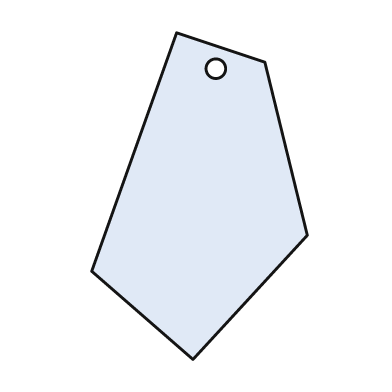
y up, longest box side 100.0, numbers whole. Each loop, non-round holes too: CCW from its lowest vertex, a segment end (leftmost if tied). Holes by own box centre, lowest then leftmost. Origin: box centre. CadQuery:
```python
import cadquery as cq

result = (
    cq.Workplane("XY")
    .moveTo(-2.0, -50.0)
    .lineTo(33.0, -12.0)
    .lineTo(20.0, 41.0)
    .lineTo(-7.0, 50.0)
    .lineTo(-33.0, -23.0)
    .close()
    .moveTo(5.0, 39.0)
    .circle(3.0)
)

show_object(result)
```